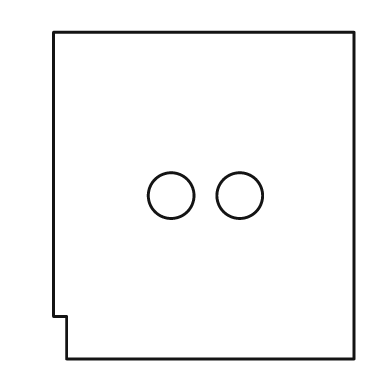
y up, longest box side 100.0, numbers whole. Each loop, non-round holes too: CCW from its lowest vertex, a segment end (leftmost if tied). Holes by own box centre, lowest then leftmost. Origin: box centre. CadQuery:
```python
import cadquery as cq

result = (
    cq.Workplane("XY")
    .moveTo(-42.0, -50.0)
    .lineTo(46.0, -50.0)
    .lineTo(46.0, 50.0)
    .lineTo(-46.0, 50.0)
    .lineTo(-46.0, -37.0)
    .lineTo(-42.0, -37.0)
    .close()
    .moveTo(-10.0, 0.0)
    .circle(7.0)
    .moveTo(11.0, 0.0)
    .circle(7.0)
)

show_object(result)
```